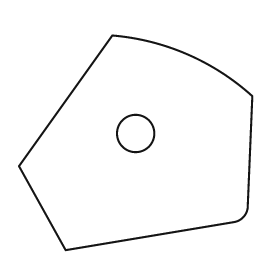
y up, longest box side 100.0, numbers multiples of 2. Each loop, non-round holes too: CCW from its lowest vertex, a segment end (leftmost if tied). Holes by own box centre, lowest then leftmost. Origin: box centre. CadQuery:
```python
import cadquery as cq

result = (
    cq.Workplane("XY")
    .moveTo(-30.0, -46.0)
    .lineTo(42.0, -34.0)
    .threePointArc((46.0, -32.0), (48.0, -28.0))
    .lineTo(50.0, 20.0)
    .threePointArc((22.0, 38.0), (-10.0, 46.0))
    .lineTo(-50.0, -10.0)
    .close()
    .moveTo(0.0, 4.0)
    .circle(8.0)
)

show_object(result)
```